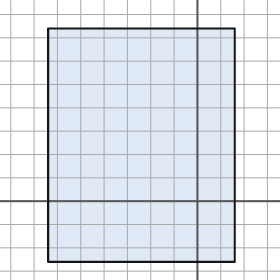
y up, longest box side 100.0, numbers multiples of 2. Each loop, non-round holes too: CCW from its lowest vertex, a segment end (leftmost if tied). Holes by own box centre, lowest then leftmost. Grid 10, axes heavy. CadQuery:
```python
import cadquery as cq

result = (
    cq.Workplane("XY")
    .moveTo(-64.0, -26.0)
    .lineTo(16.0, -26.0)
    .lineTo(16.0, 74.0)
    .lineTo(-64.0, 74.0)
    .close()
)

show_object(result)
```